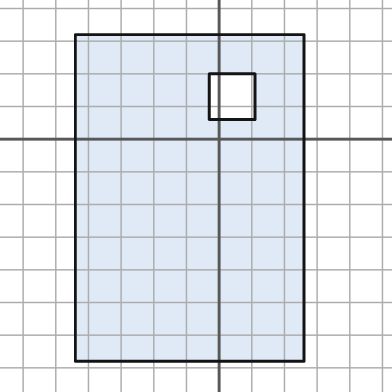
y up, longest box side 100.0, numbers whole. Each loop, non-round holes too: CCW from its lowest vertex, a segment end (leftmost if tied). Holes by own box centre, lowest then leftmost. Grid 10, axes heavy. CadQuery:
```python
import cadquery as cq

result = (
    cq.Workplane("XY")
    .moveTo(-44.0, -68.0)
    .lineTo(26.0, -68.0)
    .lineTo(26.0, 32.0)
    .lineTo(-44.0, 32.0)
    .close()
    .moveTo(-3.0, 6.0)
    .lineTo(11.0, 6.0)
    .lineTo(11.0, 20.0)
    .lineTo(-3.0, 20.0)
    .close()
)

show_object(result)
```